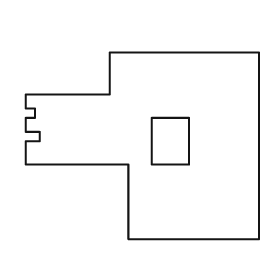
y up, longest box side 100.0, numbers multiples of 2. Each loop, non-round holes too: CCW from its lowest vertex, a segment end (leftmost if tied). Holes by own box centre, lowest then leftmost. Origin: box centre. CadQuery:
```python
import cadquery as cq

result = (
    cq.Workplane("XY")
    .moveTo(-6.0, -40.0)
    .lineTo(50.0, -40.0)
    .lineTo(50.0, 40.0)
    .lineTo(-14.0, 40.0)
    .lineTo(-14.0, 22.0)
    .lineTo(-50.0, 22.0)
    .lineTo(-50.0, 16.0)
    .lineTo(-46.0, 16.0)
    .lineTo(-46.0, 12.0)
    .lineTo(-50.0, 12.0)
    .lineTo(-50.0, 6.0)
    .lineTo(-44.0, 6.0)
    .lineTo(-44.0, 2.0)
    .lineTo(-50.0, 2.0)
    .lineTo(-50.0, -8.0)
    .lineTo(-6.0, -8.0)
    .close()
    .moveTo(4.0, -8.0)
    .lineTo(20.0, -8.0)
    .lineTo(20.0, 12.0)
    .lineTo(4.0, 12.0)
    .close()
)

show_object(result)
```